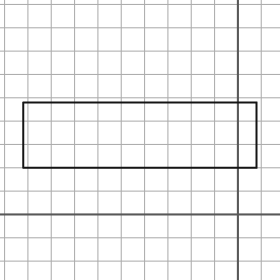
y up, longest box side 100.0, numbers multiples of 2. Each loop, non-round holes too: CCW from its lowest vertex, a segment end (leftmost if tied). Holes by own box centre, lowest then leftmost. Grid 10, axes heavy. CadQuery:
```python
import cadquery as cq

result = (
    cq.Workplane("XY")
    .moveTo(-92.0, 20.0)
    .lineTo(8.0, 20.0)
    .lineTo(8.0, 48.0)
    .lineTo(-92.0, 48.0)
    .close()
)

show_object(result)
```